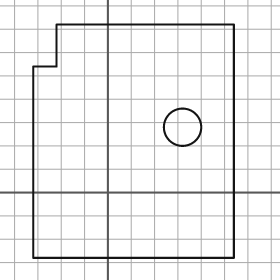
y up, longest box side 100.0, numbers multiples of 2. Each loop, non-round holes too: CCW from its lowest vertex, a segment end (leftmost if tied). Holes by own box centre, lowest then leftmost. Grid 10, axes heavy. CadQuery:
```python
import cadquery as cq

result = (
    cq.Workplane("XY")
    .moveTo(-32.0, -28.0)
    .lineTo(54.0, -28.0)
    .lineTo(54.0, 72.0)
    .lineTo(-22.0, 72.0)
    .lineTo(-22.0, 54.0)
    .lineTo(-32.0, 54.0)
    .close()
    .moveTo(32.0, 28.0)
    .circle(8.0)
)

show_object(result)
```